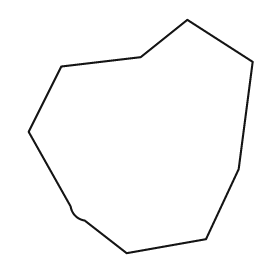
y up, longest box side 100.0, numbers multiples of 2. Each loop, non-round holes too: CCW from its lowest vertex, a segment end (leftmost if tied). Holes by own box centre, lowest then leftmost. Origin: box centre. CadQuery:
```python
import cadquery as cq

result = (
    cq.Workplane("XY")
    .moveTo(-6.0, -50.0)
    .lineTo(28.0, -44.0)
    .lineTo(42.0, -14.0)
    .lineTo(48.0, 32.0)
    .lineTo(20.0, 50.0)
    .lineTo(0.0, 34.0)
    .lineTo(-34.0, 30.0)
    .lineTo(-48.0, 2.0)
    .lineTo(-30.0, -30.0)
    .threePointArc((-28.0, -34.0), (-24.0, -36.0))
    .close()
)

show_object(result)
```